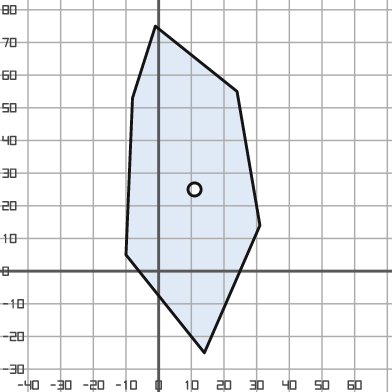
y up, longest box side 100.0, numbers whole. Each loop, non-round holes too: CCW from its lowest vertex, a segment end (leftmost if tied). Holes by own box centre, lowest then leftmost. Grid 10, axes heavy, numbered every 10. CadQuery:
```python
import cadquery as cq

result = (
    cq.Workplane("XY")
    .moveTo(14.0, -25.0)
    .lineTo(31.0, 14.0)
    .lineTo(24.0, 55.0)
    .lineTo(-1.0, 75.0)
    .lineTo(-8.0, 53.0)
    .lineTo(-10.0, 5.0)
    .close()
    .moveTo(11.0, 25.0)
    .circle(2.0)
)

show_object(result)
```